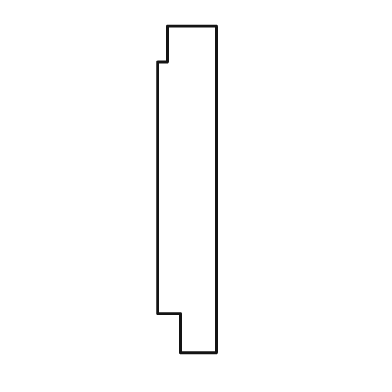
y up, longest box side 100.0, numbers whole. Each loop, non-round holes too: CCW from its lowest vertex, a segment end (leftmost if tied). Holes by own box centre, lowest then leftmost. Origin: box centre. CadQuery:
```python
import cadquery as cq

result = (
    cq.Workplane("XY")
    .moveTo(-2.0, -50.0)
    .lineTo(9.0, -50.0)
    .lineTo(9.0, 50.0)
    .lineTo(-6.0, 50.0)
    .lineTo(-6.0, 39.0)
    .lineTo(-9.0, 39.0)
    .lineTo(-9.0, -38.0)
    .lineTo(-2.0, -38.0)
    .close()
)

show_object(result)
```